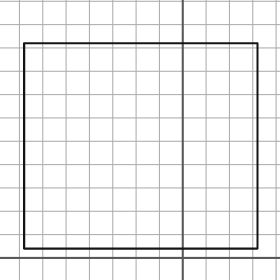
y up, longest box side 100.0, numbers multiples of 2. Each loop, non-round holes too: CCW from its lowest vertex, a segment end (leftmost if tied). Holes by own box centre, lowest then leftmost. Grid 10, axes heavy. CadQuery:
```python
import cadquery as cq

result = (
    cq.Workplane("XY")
    .moveTo(-68.0, 4.0)
    .lineTo(32.0, 4.0)
    .lineTo(32.0, 92.0)
    .lineTo(-68.0, 92.0)
    .close()
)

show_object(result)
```